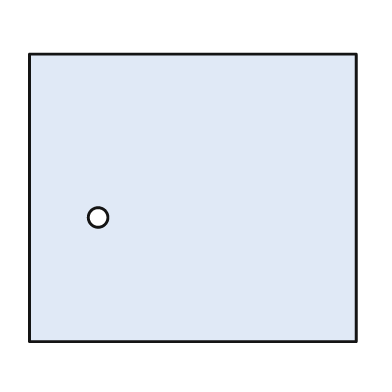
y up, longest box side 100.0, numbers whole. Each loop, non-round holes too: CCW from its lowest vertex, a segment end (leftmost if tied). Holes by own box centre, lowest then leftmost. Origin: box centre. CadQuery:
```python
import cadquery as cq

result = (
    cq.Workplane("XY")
    .moveTo(-50.0, -44.0)
    .lineTo(50.0, -44.0)
    .lineTo(50.0, 44.0)
    .lineTo(-50.0, 44.0)
    .close()
    .moveTo(-29.0, -6.0)
    .circle(3.0)
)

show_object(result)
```